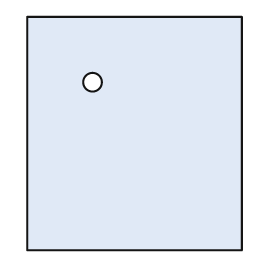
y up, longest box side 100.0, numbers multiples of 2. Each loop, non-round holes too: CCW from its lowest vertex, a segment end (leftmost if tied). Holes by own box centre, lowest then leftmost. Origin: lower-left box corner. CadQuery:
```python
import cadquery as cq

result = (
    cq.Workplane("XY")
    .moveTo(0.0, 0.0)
    .lineTo(92.0, 0.0)
    .lineTo(92.0, 100.0)
    .lineTo(0.0, 100.0)
    .close()
    .moveTo(28.0, 72.0)
    .circle(4.0)
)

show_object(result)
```